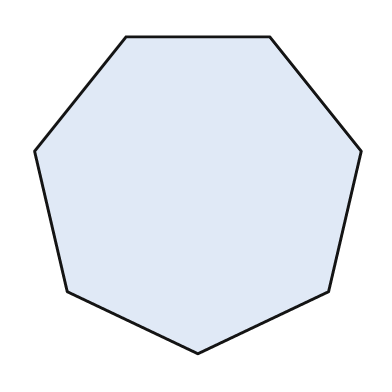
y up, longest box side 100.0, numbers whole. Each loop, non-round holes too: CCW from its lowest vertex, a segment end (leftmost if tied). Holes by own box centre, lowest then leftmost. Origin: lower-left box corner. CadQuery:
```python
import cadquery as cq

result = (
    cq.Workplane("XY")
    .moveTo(50.0, 0.0)
    .lineTo(90.0, 19.0)
    .lineTo(100.0, 62.0)
    .lineTo(72.0, 97.0)
    .lineTo(28.0, 97.0)
    .lineTo(0.0, 62.0)
    .lineTo(10.0, 19.0)
    .close()
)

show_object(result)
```